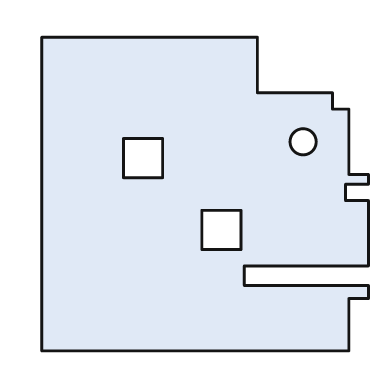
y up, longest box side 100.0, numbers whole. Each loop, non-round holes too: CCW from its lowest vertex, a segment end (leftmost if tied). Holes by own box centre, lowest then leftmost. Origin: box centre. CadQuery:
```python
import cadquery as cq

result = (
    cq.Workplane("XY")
    .moveTo(-50.0, -48.0)
    .lineTo(44.0, -48.0)
    .lineTo(44.0, -32.0)
    .lineTo(50.0, -32.0)
    .lineTo(50.0, -28.0)
    .lineTo(12.0, -28.0)
    .lineTo(12.0, -22.0)
    .lineTo(50.0, -22.0)
    .lineTo(50.0, -2.0)
    .lineTo(43.0, -2.0)
    .lineTo(43.0, 3.0)
    .lineTo(50.0, 3.0)
    .lineTo(50.0, 6.0)
    .lineTo(44.0, 6.0)
    .lineTo(44.0, 26.0)
    .lineTo(39.0, 26.0)
    .lineTo(39.0, 31.0)
    .lineTo(16.0, 31.0)
    .lineTo(16.0, 48.0)
    .lineTo(-50.0, 48.0)
    .close()
    .moveTo(-1.0, -17.0)
    .lineTo(11.0, -17.0)
    .lineTo(11.0, -5.0)
    .lineTo(-1.0, -5.0)
    .close()
    .moveTo(-25.0, 5.0)
    .lineTo(-13.0, 5.0)
    .lineTo(-13.0, 17.0)
    .lineTo(-25.0, 17.0)
    .close()
    .moveTo(30.0, 16.0)
    .circle(4.0)
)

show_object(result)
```